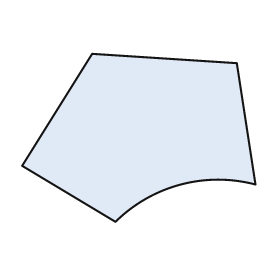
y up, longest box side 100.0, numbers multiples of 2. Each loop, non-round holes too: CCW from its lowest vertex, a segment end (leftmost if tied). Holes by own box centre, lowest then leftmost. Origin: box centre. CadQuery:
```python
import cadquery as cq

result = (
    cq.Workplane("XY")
    .moveTo(-10.0, -36.0)
    .threePointArc((18.0, -20.0), (50.0, -20.0))
    .lineTo(42.0, 32.0)
    .lineTo(-20.0, 36.0)
    .lineTo(-50.0, -12.0)
    .close()
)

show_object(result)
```